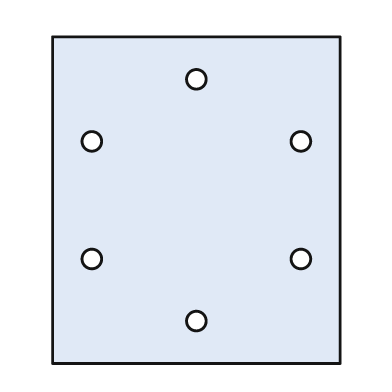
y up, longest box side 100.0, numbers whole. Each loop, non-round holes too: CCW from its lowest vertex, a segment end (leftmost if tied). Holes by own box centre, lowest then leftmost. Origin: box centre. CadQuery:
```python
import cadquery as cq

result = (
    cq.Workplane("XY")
    .moveTo(-44.0, -50.0)
    .lineTo(44.0, -50.0)
    .lineTo(44.0, 50.0)
    .lineTo(-44.0, 50.0)
    .close()
    .moveTo(0.0, -37.0)
    .circle(3.0)
    .moveTo(-32.0, -18.0)
    .circle(3.0)
    .moveTo(32.0, -18.0)
    .circle(3.0)
    .moveTo(-32.0, 18.0)
    .circle(3.0)
    .moveTo(32.0, 18.0)
    .circle(3.0)
    .moveTo(0.0, 37.0)
    .circle(3.0)
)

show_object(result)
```